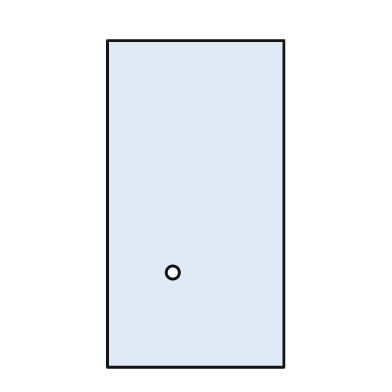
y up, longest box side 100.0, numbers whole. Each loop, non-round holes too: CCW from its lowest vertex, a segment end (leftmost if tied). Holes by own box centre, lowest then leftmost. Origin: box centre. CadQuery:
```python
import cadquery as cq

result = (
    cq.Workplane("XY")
    .moveTo(-27.0, -50.0)
    .lineTo(27.0, -50.0)
    .lineTo(27.0, 50.0)
    .lineTo(-27.0, 50.0)
    .close()
    .moveTo(-7.0, -21.0)
    .circle(2.0)
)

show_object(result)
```